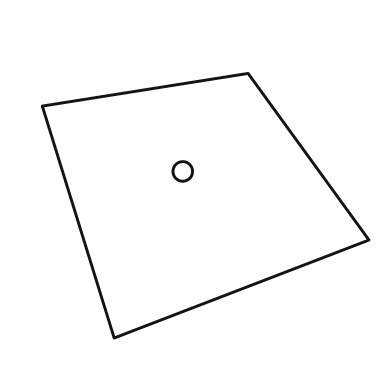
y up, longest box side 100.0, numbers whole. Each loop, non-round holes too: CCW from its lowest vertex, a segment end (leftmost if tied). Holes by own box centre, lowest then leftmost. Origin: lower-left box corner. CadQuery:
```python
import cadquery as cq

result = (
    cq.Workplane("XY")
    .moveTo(22.0, 0.0)
    .lineTo(100.0, 30.0)
    .lineTo(63.0, 81.0)
    .lineTo(0.0, 71.0)
    .close()
    .moveTo(43.0, 51.0)
    .circle(3.0)
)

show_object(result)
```